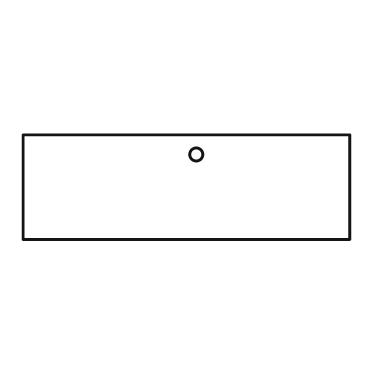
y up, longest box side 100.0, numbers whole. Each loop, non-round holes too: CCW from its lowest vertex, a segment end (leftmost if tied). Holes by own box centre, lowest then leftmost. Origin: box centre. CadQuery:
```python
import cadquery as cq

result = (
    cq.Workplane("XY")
    .moveTo(-50.0, -16.0)
    .lineTo(50.0, -16.0)
    .lineTo(50.0, 16.0)
    .lineTo(-50.0, 16.0)
    .close()
    .moveTo(3.0, 10.0)
    .circle(2.0)
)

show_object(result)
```